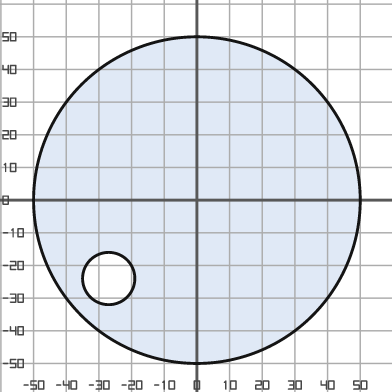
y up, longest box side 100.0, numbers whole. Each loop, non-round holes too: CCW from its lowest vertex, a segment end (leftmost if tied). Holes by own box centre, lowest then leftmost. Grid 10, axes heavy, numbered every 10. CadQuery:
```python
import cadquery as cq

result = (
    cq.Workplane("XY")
    .moveTo(0.0, 0.0)
    .circle(50.0)
    .moveTo(-27.0, -24.0)
    .circle(8.0)
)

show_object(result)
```